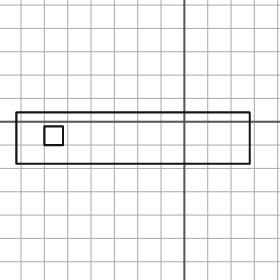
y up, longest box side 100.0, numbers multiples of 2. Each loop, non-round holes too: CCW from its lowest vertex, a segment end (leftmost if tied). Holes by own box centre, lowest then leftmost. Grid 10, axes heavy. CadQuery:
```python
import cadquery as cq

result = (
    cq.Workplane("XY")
    .moveTo(-72.0, -18.0)
    .lineTo(28.0, -18.0)
    .lineTo(28.0, 4.0)
    .lineTo(-72.0, 4.0)
    .close()
    .moveTo(-60.0, -10.0)
    .lineTo(-52.0, -10.0)
    .lineTo(-52.0, -2.0)
    .lineTo(-60.0, -2.0)
    .close()
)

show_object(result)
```